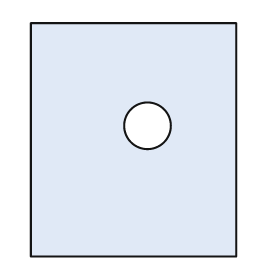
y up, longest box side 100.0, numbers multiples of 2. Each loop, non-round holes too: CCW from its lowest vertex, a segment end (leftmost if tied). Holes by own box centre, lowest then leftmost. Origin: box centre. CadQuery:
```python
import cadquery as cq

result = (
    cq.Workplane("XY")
    .moveTo(-44.0, -50.0)
    .lineTo(44.0, -50.0)
    .lineTo(44.0, 50.0)
    .lineTo(-44.0, 50.0)
    .close()
    .moveTo(6.0, 6.0)
    .circle(10.0)
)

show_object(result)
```